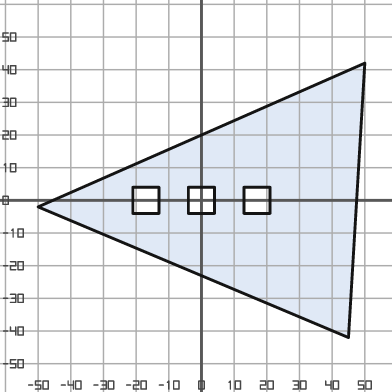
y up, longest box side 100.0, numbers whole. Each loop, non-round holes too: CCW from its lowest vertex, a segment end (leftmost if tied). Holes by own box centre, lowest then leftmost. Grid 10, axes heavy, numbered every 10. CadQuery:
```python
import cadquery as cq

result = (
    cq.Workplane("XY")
    .moveTo(45.0, -42.0)
    .lineTo(50.0, 42.0)
    .lineTo(-50.0, -2.0)
    .close()
    .moveTo(-21.0, -4.0)
    .lineTo(-13.0, -4.0)
    .lineTo(-13.0, 4.0)
    .lineTo(-21.0, 4.0)
    .close()
    .moveTo(-4.0, -4.0)
    .lineTo(4.0, -4.0)
    .lineTo(4.0, 4.0)
    .lineTo(-4.0, 4.0)
    .close()
    .moveTo(13.0, -4.0)
    .lineTo(21.0, -4.0)
    .lineTo(21.0, 4.0)
    .lineTo(13.0, 4.0)
    .close()
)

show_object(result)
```